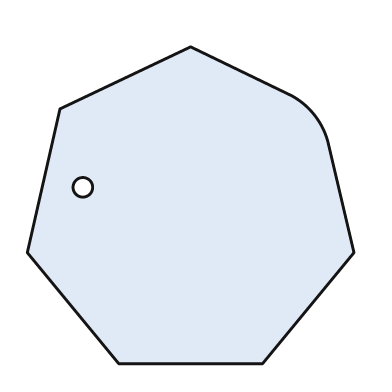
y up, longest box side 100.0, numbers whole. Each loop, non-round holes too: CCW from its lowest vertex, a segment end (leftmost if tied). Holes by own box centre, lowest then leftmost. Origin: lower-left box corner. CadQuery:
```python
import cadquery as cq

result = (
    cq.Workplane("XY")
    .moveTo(28.0, 0.0)
    .lineTo(72.0, 0.0)
    .lineTo(100.0, 34.0)
    .lineTo(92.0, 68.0)
    .threePointArc((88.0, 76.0), (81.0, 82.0))
    .lineTo(50.0, 97.0)
    .lineTo(10.0, 78.0)
    .lineTo(0.0, 34.0)
    .close()
    .moveTo(17.0, 54.0)
    .circle(3.0)
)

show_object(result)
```